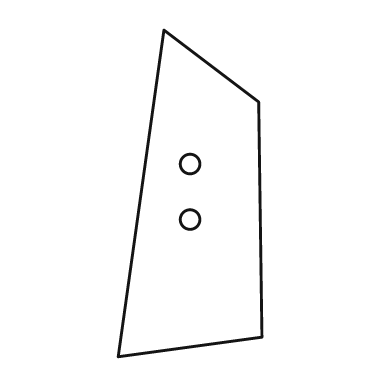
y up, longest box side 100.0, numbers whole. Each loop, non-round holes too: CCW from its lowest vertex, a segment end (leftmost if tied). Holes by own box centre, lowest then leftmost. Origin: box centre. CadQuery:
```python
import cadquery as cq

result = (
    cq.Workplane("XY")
    .moveTo(-22.0, -50.0)
    .lineTo(22.0, -44.0)
    .lineTo(21.0, 28.0)
    .lineTo(-8.0, 50.0)
    .close()
    .moveTo(0.0, -8.0)
    .circle(3.0)
    .moveTo(0.0, 9.0)
    .circle(3.0)
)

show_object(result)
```